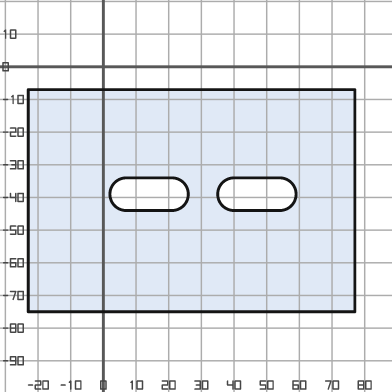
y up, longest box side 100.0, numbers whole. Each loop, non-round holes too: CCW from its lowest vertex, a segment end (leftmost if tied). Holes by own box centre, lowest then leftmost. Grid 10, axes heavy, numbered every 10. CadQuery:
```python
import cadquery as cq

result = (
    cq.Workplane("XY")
    .moveTo(-23.0, -75.0)
    .lineTo(77.0, -75.0)
    .lineTo(77.0, -7.0)
    .lineTo(-23.0, -7.0)
    .close()
    .moveTo(7.0, -44.0)
    .lineTo(21.0, -44.0)
    .threePointArc((26.0, -39.0), (21.0, -34.0))
    .lineTo(7.0, -34.0)
    .threePointArc((2.0, -39.0), (7.0, -44.0))
    .close()
    .moveTo(40.0, -44.0)
    .lineTo(54.0, -44.0)
    .threePointArc((59.0, -39.0), (54.0, -34.0))
    .lineTo(40.0, -34.0)
    .threePointArc((35.0, -39.0), (40.0, -44.0))
    .close()
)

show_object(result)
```